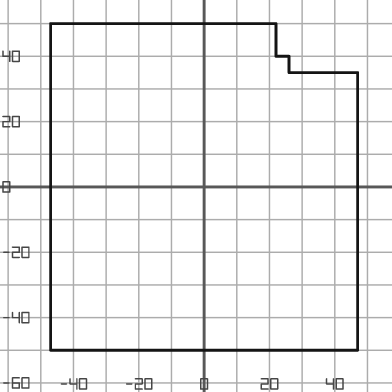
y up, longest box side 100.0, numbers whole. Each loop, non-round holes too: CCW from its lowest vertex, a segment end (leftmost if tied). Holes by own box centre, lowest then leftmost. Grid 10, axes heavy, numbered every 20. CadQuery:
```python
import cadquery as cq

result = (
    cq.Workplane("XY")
    .moveTo(-47.0, -50.0)
    .lineTo(47.0, -50.0)
    .lineTo(47.0, 35.0)
    .lineTo(26.0, 35.0)
    .lineTo(26.0, 40.0)
    .lineTo(22.0, 40.0)
    .lineTo(22.0, 50.0)
    .lineTo(-47.0, 50.0)
    .close()
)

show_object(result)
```